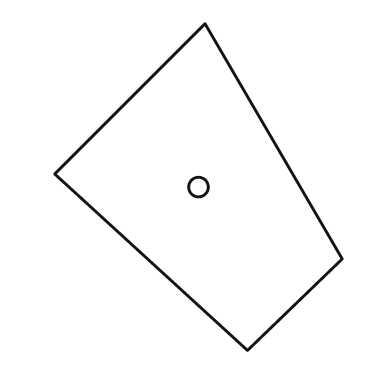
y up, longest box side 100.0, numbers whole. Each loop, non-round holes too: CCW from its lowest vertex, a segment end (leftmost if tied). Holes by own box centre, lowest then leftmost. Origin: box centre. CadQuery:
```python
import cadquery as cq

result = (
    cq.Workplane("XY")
    .moveTo(15.0, -50.0)
    .lineTo(44.0, -22.0)
    .lineTo(2.0, 50.0)
    .lineTo(-44.0, 4.0)
    .close()
    .moveTo(0.0, 0.0)
    .circle(3.0)
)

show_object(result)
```